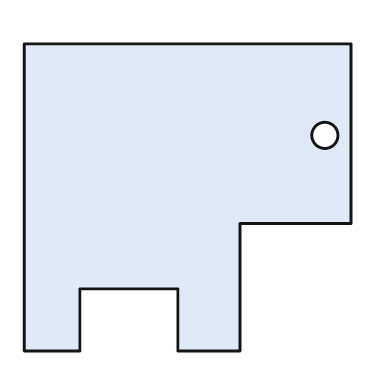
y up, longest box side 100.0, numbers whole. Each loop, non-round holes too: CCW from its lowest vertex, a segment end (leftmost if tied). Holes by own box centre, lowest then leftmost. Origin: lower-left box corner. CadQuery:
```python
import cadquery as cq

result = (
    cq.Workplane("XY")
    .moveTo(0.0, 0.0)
    .lineTo(17.0, 0.0)
    .lineTo(17.0, 19.0)
    .lineTo(47.0, 19.0)
    .lineTo(47.0, 0.0)
    .lineTo(66.0, 0.0)
    .lineTo(66.0, 39.0)
    .lineTo(100.0, 39.0)
    .lineTo(100.0, 94.0)
    .lineTo(0.0, 94.0)
    .close()
    .moveTo(92.0, 66.0)
    .circle(4.0)
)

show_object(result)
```